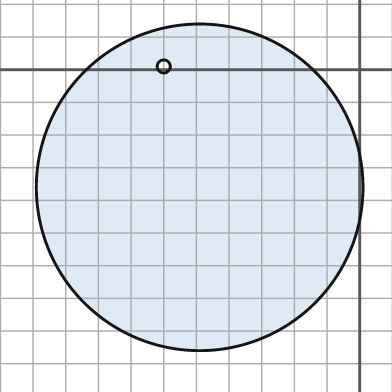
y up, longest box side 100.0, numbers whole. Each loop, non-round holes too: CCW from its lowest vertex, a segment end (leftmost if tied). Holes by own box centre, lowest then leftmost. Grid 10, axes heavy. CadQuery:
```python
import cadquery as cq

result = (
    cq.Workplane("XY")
    .moveTo(-49.0, -36.0)
    .circle(50.0)
    .moveTo(-60.0, 1.0)
    .circle(2.0)
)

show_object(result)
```